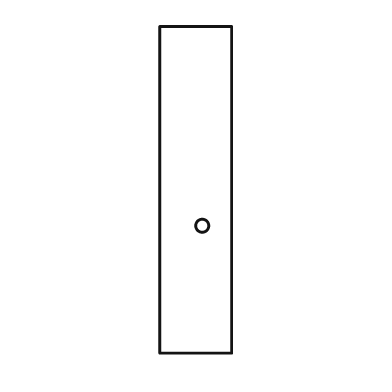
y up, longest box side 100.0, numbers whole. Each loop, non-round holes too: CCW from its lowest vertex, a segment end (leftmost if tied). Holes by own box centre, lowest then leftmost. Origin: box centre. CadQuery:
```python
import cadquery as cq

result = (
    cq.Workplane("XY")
    .moveTo(-11.0, -50.0)
    .lineTo(11.0, -50.0)
    .lineTo(11.0, 50.0)
    .lineTo(-11.0, 50.0)
    .close()
    .moveTo(2.0, -11.0)
    .circle(2.0)
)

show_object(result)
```